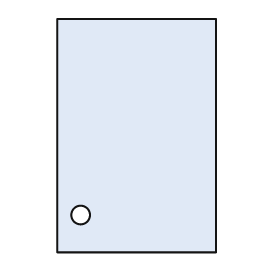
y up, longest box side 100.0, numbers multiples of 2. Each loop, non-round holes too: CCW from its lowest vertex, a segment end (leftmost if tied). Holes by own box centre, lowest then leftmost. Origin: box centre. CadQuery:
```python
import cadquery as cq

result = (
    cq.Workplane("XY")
    .moveTo(-34.0, -50.0)
    .lineTo(34.0, -50.0)
    .lineTo(34.0, 50.0)
    .lineTo(-34.0, 50.0)
    .close()
    .moveTo(-24.0, -34.0)
    .circle(4.0)
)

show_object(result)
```